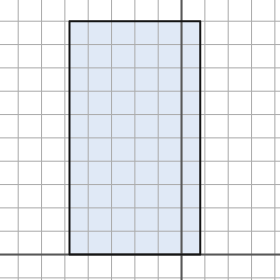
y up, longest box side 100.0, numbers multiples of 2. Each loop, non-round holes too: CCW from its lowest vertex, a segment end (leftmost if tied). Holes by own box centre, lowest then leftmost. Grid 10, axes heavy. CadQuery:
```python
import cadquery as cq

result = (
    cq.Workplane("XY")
    .moveTo(-48.0, 0.0)
    .lineTo(8.0, 0.0)
    .lineTo(8.0, 100.0)
    .lineTo(-48.0, 100.0)
    .close()
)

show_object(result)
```